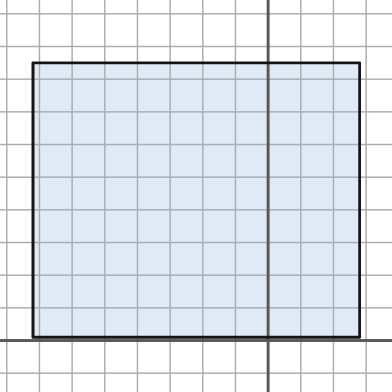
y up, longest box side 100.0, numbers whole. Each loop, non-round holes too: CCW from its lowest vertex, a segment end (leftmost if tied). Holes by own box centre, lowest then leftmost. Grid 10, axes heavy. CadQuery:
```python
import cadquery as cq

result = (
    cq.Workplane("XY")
    .moveTo(-72.0, 1.0)
    .lineTo(28.0, 1.0)
    .lineTo(28.0, 85.0)
    .lineTo(-72.0, 85.0)
    .close()
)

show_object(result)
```